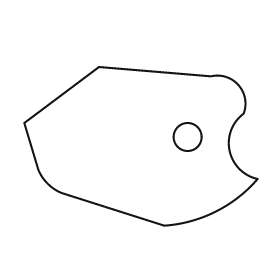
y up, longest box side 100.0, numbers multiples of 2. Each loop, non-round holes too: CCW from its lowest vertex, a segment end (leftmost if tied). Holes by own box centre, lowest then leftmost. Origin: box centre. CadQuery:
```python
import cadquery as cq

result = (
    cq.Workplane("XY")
    .moveTo(10.0, -34.0)
    .threePointArc((32.0, -28.0), (50.0, -14.0))
    .threePointArc((38.0, -2.0), (44.0, 14.0))
    .threePointArc((42.0, 26.0), (30.0, 30.0))
    .lineTo(-18.0, 34.0)
    .lineTo(-50.0, 10.0)
    .lineTo(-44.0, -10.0)
    .threePointArc((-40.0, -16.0), (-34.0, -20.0))
    .close()
    .moveTo(20.0, 4.0)
    .circle(6.0)
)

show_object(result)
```